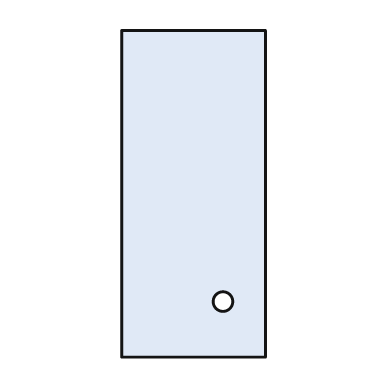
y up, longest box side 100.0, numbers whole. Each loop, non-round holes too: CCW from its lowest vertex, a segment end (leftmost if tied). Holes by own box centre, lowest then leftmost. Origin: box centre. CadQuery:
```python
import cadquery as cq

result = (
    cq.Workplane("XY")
    .moveTo(-22.0, -50.0)
    .lineTo(22.0, -50.0)
    .lineTo(22.0, 50.0)
    .lineTo(-22.0, 50.0)
    .close()
    .moveTo(9.0, -33.0)
    .circle(3.0)
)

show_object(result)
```